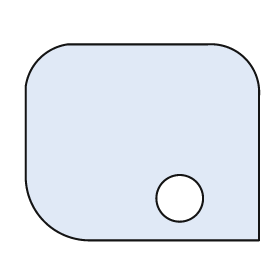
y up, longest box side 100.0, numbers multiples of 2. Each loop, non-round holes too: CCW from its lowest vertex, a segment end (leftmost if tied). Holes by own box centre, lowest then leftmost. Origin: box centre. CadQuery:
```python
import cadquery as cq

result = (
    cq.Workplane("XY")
    .moveTo(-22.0, -42.0)
    .lineTo(50.0, -42.0)
    .lineTo(50.0, 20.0)
    .threePointArc((44.0, 36.0), (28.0, 42.0))
    .lineTo(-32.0, 42.0)
    .threePointArc((-44.0, 36.0), (-50.0, 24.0))
    .lineTo(-50.0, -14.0)
    .threePointArc((-42.0, -34.0), (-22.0, -42.0))
    .close()
    .moveTo(16.0, -24.0)
    .circle(10.0)
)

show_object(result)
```